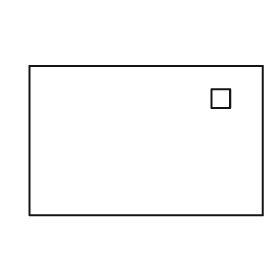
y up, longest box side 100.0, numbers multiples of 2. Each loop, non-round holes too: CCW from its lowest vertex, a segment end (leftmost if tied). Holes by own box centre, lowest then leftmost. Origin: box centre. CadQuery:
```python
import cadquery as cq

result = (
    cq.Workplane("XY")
    .moveTo(-50.0, -32.0)
    .lineTo(50.0, -32.0)
    .lineTo(50.0, 32.0)
    .lineTo(-50.0, 32.0)
    .close()
    .moveTo(28.0, 14.0)
    .lineTo(36.0, 14.0)
    .lineTo(36.0, 22.0)
    .lineTo(28.0, 22.0)
    .close()
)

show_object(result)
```